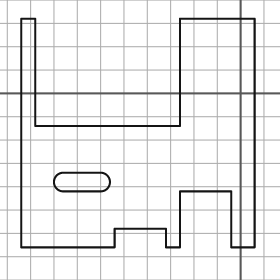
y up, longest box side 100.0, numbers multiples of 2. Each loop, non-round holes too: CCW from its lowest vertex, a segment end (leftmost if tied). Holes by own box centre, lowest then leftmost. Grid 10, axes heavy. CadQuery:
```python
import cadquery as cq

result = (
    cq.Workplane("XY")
    .moveTo(-94.0, -66.0)
    .lineTo(-54.0, -66.0)
    .lineTo(-54.0, -58.0)
    .lineTo(-32.0, -58.0)
    .lineTo(-32.0, -66.0)
    .lineTo(-26.0, -66.0)
    .lineTo(-26.0, -42.0)
    .lineTo(-4.0, -42.0)
    .lineTo(-4.0, -66.0)
    .lineTo(6.0, -66.0)
    .lineTo(6.0, 32.0)
    .lineTo(-26.0, 32.0)
    .lineTo(-26.0, -14.0)
    .lineTo(-88.0, -14.0)
    .lineTo(-88.0, 32.0)
    .lineTo(-94.0, 32.0)
    .close()
    .moveTo(-76.0, -42.0)
    .lineTo(-60.0, -42.0)
    .threePointArc((-56.0, -38.0), (-60.0, -34.0))
    .lineTo(-76.0, -34.0)
    .threePointArc((-80.0, -38.0), (-76.0, -42.0))
    .close()
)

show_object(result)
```